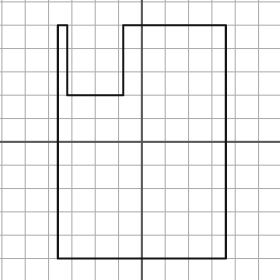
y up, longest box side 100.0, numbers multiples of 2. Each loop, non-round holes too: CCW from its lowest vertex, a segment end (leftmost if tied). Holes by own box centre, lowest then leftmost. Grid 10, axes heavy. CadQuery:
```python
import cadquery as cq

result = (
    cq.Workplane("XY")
    .moveTo(-36.0, -50.0)
    .lineTo(36.0, -50.0)
    .lineTo(36.0, 50.0)
    .lineTo(-8.0, 50.0)
    .lineTo(-8.0, 20.0)
    .lineTo(-32.0, 20.0)
    .lineTo(-32.0, 50.0)
    .lineTo(-36.0, 50.0)
    .close()
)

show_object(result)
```